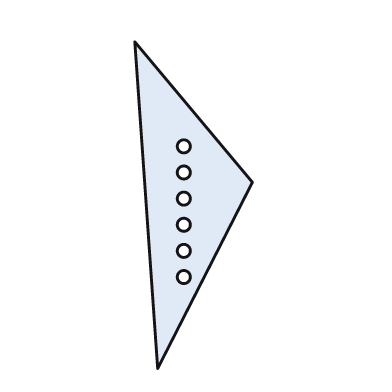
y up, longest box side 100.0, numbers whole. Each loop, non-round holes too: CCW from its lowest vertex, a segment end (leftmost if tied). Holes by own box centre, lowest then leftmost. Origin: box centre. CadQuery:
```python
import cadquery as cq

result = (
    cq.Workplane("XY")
    .moveTo(-11.0, -50.0)
    .lineTo(18.0, 7.0)
    .lineTo(-18.0, 50.0)
    .close()
    .moveTo(-3.0, -22.0)
    .circle(2.0)
    .moveTo(-3.0, -14.0)
    .circle(2.0)
    .moveTo(-3.0, -6.0)
    .circle(2.0)
    .moveTo(-3.0, 2.0)
    .circle(2.0)
    .moveTo(-3.0, 10.0)
    .circle(2.0)
    .moveTo(-3.0, 18.0)
    .circle(2.0)
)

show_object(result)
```